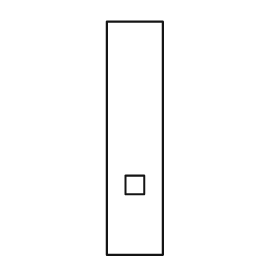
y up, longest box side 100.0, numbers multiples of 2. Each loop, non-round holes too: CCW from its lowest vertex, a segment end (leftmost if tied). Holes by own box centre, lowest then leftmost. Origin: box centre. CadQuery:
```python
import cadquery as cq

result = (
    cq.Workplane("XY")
    .moveTo(-12.0, -50.0)
    .lineTo(12.0, -50.0)
    .lineTo(12.0, 50.0)
    .lineTo(-12.0, 50.0)
    .close()
    .moveTo(-4.0, -24.0)
    .lineTo(4.0, -24.0)
    .lineTo(4.0, -16.0)
    .lineTo(-4.0, -16.0)
    .close()
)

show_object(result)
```